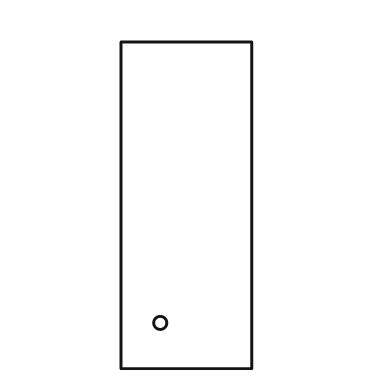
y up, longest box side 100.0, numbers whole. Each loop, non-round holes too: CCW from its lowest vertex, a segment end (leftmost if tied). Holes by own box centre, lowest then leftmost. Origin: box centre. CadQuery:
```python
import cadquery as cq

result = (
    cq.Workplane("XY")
    .moveTo(-20.0, -50.0)
    .lineTo(20.0, -50.0)
    .lineTo(20.0, 50.0)
    .lineTo(-20.0, 50.0)
    .close()
    .moveTo(-8.0, -36.0)
    .circle(2.0)
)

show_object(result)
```